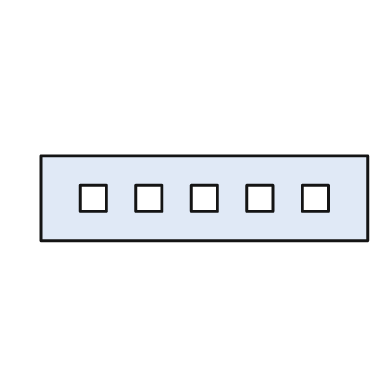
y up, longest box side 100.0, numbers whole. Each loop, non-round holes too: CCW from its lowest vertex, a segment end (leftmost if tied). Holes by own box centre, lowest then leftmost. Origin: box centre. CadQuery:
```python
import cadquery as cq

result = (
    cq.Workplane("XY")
    .moveTo(-50.0, -13.0)
    .lineTo(50.0, -13.0)
    .lineTo(50.0, 13.0)
    .lineTo(-50.0, 13.0)
    .close()
    .moveTo(-38.0, -4.0)
    .lineTo(-30.0, -4.0)
    .lineTo(-30.0, 4.0)
    .lineTo(-38.0, 4.0)
    .close()
    .moveTo(-21.0, -4.0)
    .lineTo(-13.0, -4.0)
    .lineTo(-13.0, 4.0)
    .lineTo(-21.0, 4.0)
    .close()
    .moveTo(-4.0, -4.0)
    .lineTo(4.0, -4.0)
    .lineTo(4.0, 4.0)
    .lineTo(-4.0, 4.0)
    .close()
    .moveTo(13.0, -4.0)
    .lineTo(21.0, -4.0)
    .lineTo(21.0, 4.0)
    .lineTo(13.0, 4.0)
    .close()
    .moveTo(30.0, -4.0)
    .lineTo(38.0, -4.0)
    .lineTo(38.0, 4.0)
    .lineTo(30.0, 4.0)
    .close()
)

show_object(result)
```